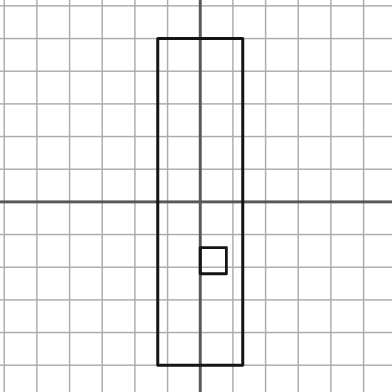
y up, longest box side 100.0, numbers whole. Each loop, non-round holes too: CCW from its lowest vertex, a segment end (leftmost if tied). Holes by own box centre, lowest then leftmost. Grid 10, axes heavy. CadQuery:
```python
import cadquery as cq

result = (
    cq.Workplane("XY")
    .moveTo(-13.0, -50.0)
    .lineTo(13.0, -50.0)
    .lineTo(13.0, 50.0)
    .lineTo(-13.0, 50.0)
    .close()
    .moveTo(0.0, -22.0)
    .lineTo(8.0, -22.0)
    .lineTo(8.0, -14.0)
    .lineTo(0.0, -14.0)
    .close()
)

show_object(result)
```